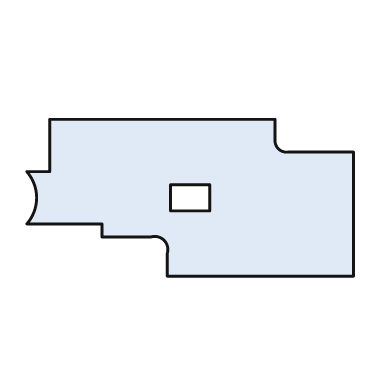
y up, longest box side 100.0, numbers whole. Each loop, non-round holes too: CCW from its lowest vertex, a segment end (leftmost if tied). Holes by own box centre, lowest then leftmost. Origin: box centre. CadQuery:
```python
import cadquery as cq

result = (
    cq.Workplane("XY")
    .moveTo(-7.0, -24.0)
    .lineTo(50.0, -24.0)
    .lineTo(50.0, 14.0)
    .lineTo(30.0, 14.0)
    .threePointArc((27.0, 15.0), (26.0, 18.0))
    .lineTo(26.0, 24.0)
    .lineTo(-43.0, 24.0)
    .lineTo(-43.0, 8.0)
    .lineTo(-50.0, 8.0)
    .threePointArc((-47.0, 0.0), (-50.0, -8.0))
    .lineTo(-27.0, -8.0)
    .lineTo(-27.0, -12.0)
    .lineTo(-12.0, -12.0)
    .threePointArc((-8.0, -13.0), (-7.0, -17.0))
    .close()
    .moveTo(-6.0, -4.0)
    .lineTo(6.0, -4.0)
    .lineTo(6.0, 4.0)
    .lineTo(-6.0, 4.0)
    .close()
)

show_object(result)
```